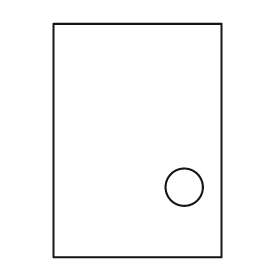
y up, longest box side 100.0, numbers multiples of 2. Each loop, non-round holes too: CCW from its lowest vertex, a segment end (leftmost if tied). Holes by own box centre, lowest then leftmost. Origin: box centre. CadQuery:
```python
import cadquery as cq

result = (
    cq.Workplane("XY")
    .moveTo(-36.0, -50.0)
    .lineTo(36.0, -50.0)
    .lineTo(36.0, 50.0)
    .lineTo(-36.0, 50.0)
    .close()
    .moveTo(20.0, -20.0)
    .circle(8.0)
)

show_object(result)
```